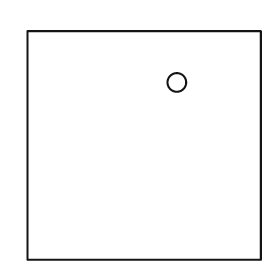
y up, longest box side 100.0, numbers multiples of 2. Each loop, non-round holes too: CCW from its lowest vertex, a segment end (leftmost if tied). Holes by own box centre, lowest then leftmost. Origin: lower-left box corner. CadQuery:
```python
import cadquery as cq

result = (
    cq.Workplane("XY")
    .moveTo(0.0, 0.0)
    .lineTo(100.0, 0.0)
    .lineTo(100.0, 98.0)
    .lineTo(0.0, 98.0)
    .close()
    .moveTo(64.0, 76.0)
    .circle(4.0)
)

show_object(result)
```